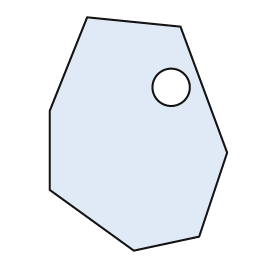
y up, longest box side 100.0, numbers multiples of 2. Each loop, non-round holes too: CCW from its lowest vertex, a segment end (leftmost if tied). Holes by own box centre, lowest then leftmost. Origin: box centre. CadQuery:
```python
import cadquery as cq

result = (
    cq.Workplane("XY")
    .moveTo(-2.0, -50.0)
    .lineTo(26.0, -44.0)
    .lineTo(38.0, -8.0)
    .lineTo(18.0, 46.0)
    .lineTo(-22.0, 50.0)
    .lineTo(-38.0, 10.0)
    .lineTo(-38.0, -24.0)
    .close()
    .moveTo(14.0, 20.0)
    .circle(8.0)
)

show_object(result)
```